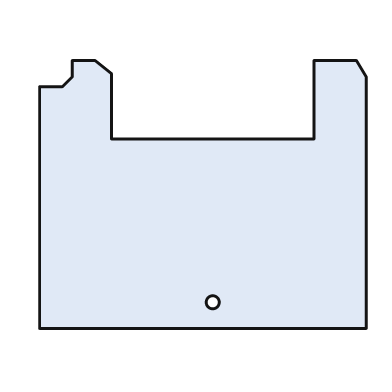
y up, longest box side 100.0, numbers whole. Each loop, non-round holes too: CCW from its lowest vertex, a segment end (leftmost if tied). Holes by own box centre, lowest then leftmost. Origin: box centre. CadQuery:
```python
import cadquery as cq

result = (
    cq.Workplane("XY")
    .moveTo(-50.0, -41.0)
    .lineTo(50.0, -41.0)
    .lineTo(50.0, 36.0)
    .lineTo(47.0, 41.0)
    .lineTo(34.0, 41.0)
    .lineTo(34.0, 17.0)
    .lineTo(-28.0, 17.0)
    .lineTo(-28.0, 37.0)
    .lineTo(-33.0, 41.0)
    .lineTo(-40.0, 41.0)
    .lineTo(-40.0, 36.0)
    .lineTo(-43.0, 33.0)
    .lineTo(-50.0, 33.0)
    .close()
    .moveTo(3.0, -33.0)
    .circle(2.0)
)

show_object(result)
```